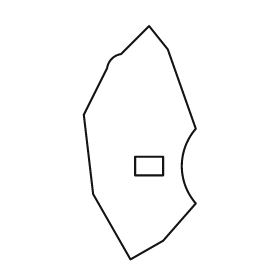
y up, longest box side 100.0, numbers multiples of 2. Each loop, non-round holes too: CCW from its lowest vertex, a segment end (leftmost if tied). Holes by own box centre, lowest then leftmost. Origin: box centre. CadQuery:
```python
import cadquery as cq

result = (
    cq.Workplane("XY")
    .moveTo(-4.0, -50.0)
    .lineTo(10.0, -42.0)
    .lineTo(24.0, -26.0)
    .threePointArc((18.0, -10.0), (24.0, 6.0))
    .lineTo(12.0, 40.0)
    .lineTo(4.0, 50.0)
    .lineTo(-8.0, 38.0)
    .threePointArc((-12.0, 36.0), (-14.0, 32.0))
    .lineTo(-24.0, 12.0)
    .lineTo(-20.0, -22.0)
    .close()
    .moveTo(-2.0, -14.0)
    .lineTo(10.0, -14.0)
    .lineTo(10.0, -6.0)
    .lineTo(-2.0, -6.0)
    .close()
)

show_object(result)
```